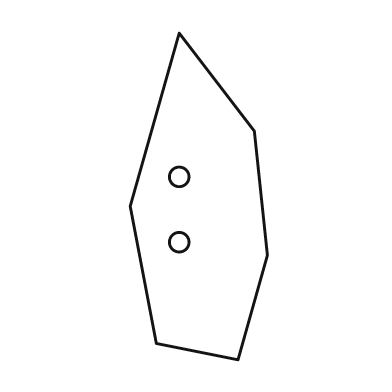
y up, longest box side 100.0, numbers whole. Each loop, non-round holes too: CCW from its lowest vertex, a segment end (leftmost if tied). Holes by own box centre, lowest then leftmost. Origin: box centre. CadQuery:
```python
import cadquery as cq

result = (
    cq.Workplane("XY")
    .moveTo(12.0, -50.0)
    .lineTo(21.0, -18.0)
    .lineTo(17.0, 20.0)
    .lineTo(-6.0, 50.0)
    .lineTo(-21.0, -3.0)
    .lineTo(-13.0, -45.0)
    .close()
    .moveTo(-6.0, -14.0)
    .circle(3.0)
    .moveTo(-6.0, 6.0)
    .circle(3.0)
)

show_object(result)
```